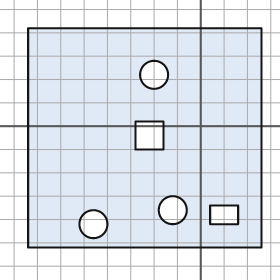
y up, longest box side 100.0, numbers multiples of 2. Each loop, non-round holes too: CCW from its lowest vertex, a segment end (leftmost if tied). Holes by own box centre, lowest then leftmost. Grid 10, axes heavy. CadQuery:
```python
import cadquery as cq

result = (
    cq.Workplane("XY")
    .moveTo(-74.0, -52.0)
    .lineTo(26.0, -52.0)
    .lineTo(26.0, 42.0)
    .lineTo(-74.0, 42.0)
    .close()
    .moveTo(-46.0, -42.0)
    .circle(6.0)
    .moveTo(4.0, -42.0)
    .lineTo(16.0, -42.0)
    .lineTo(16.0, -34.0)
    .lineTo(4.0, -34.0)
    .close()
    .moveTo(-12.0, -36.0)
    .circle(6.0)
    .moveTo(-28.0, -10.0)
    .lineTo(-16.0, -10.0)
    .lineTo(-16.0, 2.0)
    .lineTo(-28.0, 2.0)
    .close()
    .moveTo(-20.0, 22.0)
    .circle(6.0)
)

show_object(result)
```